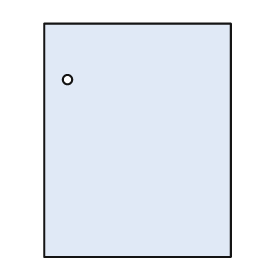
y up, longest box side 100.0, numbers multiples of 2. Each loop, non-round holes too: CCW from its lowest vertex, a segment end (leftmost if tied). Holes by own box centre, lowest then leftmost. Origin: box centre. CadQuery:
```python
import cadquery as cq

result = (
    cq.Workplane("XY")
    .moveTo(-40.0, -50.0)
    .lineTo(40.0, -50.0)
    .lineTo(40.0, 50.0)
    .lineTo(-40.0, 50.0)
    .close()
    .moveTo(-30.0, 26.0)
    .circle(2.0)
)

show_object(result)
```